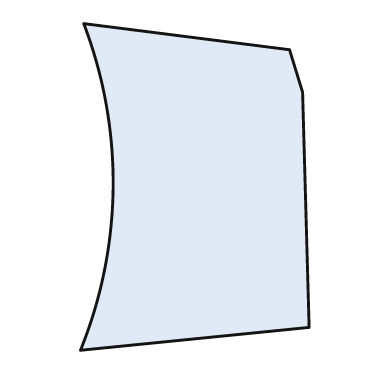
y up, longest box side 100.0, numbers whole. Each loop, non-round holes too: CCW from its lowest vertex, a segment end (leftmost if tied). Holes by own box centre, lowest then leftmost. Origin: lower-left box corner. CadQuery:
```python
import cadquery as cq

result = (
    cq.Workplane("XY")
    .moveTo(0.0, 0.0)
    .lineTo(70.0, 7.0)
    .lineTo(68.0, 79.0)
    .lineTo(64.0, 92.0)
    .lineTo(1.0, 100.0)
    .threePointArc((10.0, 50.0), (0.0, 0.0))
    .close()
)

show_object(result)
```